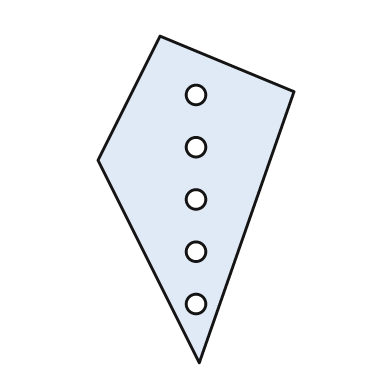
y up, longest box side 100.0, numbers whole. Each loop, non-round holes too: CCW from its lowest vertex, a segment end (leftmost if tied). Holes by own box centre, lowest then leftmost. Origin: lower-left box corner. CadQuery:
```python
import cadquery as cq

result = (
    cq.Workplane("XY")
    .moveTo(31.0, 0.0)
    .lineTo(60.0, 83.0)
    .lineTo(19.0, 100.0)
    .lineTo(0.0, 62.0)
    .close()
    .moveTo(30.0, 18.0)
    .circle(3.0)
    .moveTo(30.0, 34.0)
    .circle(3.0)
    .moveTo(30.0, 50.0)
    .circle(3.0)
    .moveTo(30.0, 66.0)
    .circle(3.0)
    .moveTo(30.0, 82.0)
    .circle(3.0)
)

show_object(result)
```